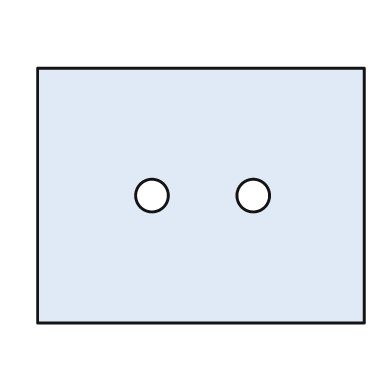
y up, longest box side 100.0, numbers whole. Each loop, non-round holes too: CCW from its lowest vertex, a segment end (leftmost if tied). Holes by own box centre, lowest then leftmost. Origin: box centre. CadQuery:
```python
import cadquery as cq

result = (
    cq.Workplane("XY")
    .moveTo(-50.0, -39.0)
    .lineTo(50.0, -39.0)
    .lineTo(50.0, 39.0)
    .lineTo(-50.0, 39.0)
    .close()
    .moveTo(-15.0, 0.0)
    .circle(5.0)
    .moveTo(16.0, 0.0)
    .circle(5.0)
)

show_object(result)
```